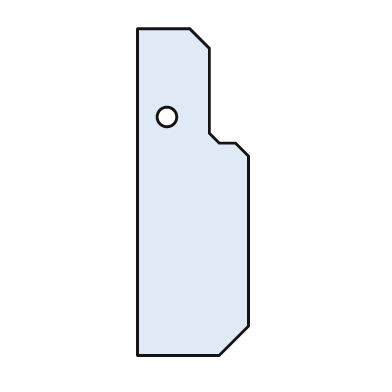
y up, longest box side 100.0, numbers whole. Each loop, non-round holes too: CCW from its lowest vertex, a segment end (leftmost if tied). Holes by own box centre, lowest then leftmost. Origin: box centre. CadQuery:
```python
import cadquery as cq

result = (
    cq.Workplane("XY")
    .moveTo(-17.0, -50.0)
    .lineTo(8.0, -50.0)
    .lineTo(17.0, -41.0)
    .lineTo(17.0, 11.0)
    .lineTo(13.0, 15.0)
    .lineTo(8.0, 15.0)
    .lineTo(5.0, 18.0)
    .lineTo(5.0, 44.0)
    .lineTo(-1.0, 50.0)
    .lineTo(-17.0, 50.0)
    .close()
    .moveTo(-8.0, 23.0)
    .circle(3.0)
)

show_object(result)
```